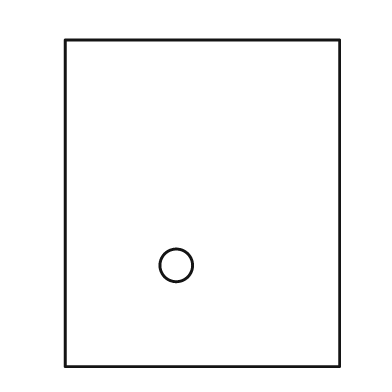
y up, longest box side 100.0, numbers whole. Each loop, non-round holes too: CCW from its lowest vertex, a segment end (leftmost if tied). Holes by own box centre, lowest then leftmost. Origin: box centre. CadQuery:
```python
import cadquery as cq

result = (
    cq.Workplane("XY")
    .moveTo(-42.0, -50.0)
    .lineTo(42.0, -50.0)
    .lineTo(42.0, 50.0)
    .lineTo(-42.0, 50.0)
    .close()
    .moveTo(-8.0, -19.0)
    .circle(5.0)
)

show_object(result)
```